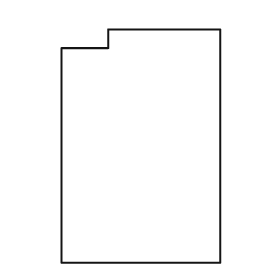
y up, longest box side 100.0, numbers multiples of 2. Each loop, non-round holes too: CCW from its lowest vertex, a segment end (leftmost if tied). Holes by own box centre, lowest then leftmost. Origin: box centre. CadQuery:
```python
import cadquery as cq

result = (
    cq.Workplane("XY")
    .moveTo(-34.0, -50.0)
    .lineTo(34.0, -50.0)
    .lineTo(34.0, 50.0)
    .lineTo(-14.0, 50.0)
    .lineTo(-14.0, 42.0)
    .lineTo(-34.0, 42.0)
    .close()
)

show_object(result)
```